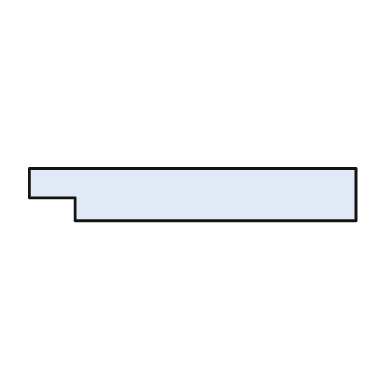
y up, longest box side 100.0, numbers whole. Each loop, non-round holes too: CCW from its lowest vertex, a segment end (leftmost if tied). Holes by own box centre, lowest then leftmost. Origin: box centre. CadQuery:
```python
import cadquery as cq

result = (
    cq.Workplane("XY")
    .moveTo(-36.0, -8.0)
    .lineTo(50.0, -8.0)
    .lineTo(50.0, 8.0)
    .lineTo(-50.0, 8.0)
    .lineTo(-50.0, -1.0)
    .lineTo(-36.0, -1.0)
    .close()
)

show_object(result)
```